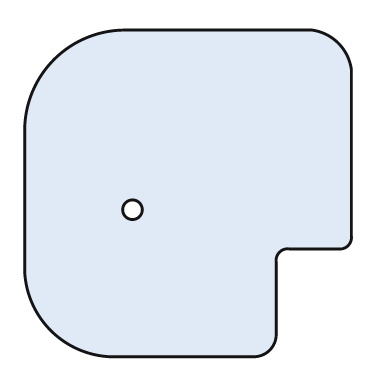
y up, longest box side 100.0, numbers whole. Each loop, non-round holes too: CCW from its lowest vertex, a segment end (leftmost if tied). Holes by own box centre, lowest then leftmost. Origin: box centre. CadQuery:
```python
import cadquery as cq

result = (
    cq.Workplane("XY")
    .moveTo(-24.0, -50.0)
    .lineTo(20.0, -50.0)
    .threePointArc((25.0, -48.0), (27.0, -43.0))
    .lineTo(27.0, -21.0)
    .threePointArc((28.0, -18.0), (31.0, -17.0))
    .lineTo(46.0, -17.0)
    .threePointArc((49.0, -16.0), (50.0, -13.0))
    .lineTo(50.0, 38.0)
    .threePointArc((46.0, 46.0), (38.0, 50.0))
    .lineTo(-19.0, 50.0)
    .threePointArc((-41.0, 41.0), (-50.0, 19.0))
    .lineTo(-50.0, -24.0)
    .threePointArc((-42.0, -42.0), (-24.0, -50.0))
    .close()
    .moveTo(-17.0, -5.0)
    .circle(3.0)
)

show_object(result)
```